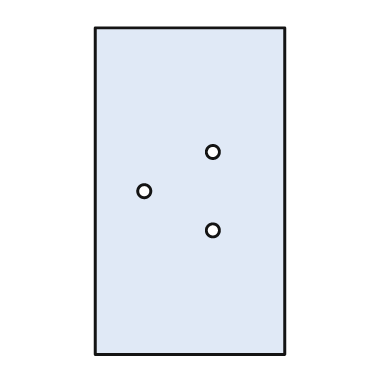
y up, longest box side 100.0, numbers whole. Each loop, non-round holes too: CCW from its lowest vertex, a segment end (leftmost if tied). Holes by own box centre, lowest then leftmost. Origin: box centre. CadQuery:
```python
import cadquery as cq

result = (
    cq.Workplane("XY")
    .moveTo(-29.0, -50.0)
    .lineTo(29.0, -50.0)
    .lineTo(29.0, 50.0)
    .lineTo(-29.0, 50.0)
    .close()
    .moveTo(7.0, -12.0)
    .circle(2.0)
    .moveTo(-14.0, 0.0)
    .circle(2.0)
    .moveTo(7.0, 12.0)
    .circle(2.0)
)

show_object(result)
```